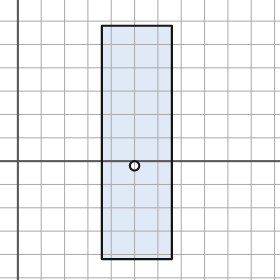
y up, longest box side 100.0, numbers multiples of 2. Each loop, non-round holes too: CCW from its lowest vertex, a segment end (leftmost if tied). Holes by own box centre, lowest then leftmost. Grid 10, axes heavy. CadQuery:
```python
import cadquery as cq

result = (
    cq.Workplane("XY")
    .moveTo(36.0, -42.0)
    .lineTo(66.0, -42.0)
    .lineTo(66.0, 58.0)
    .lineTo(36.0, 58.0)
    .close()
    .moveTo(50.0, -2.0)
    .circle(2.0)
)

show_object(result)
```